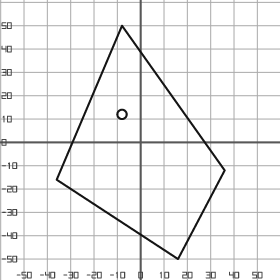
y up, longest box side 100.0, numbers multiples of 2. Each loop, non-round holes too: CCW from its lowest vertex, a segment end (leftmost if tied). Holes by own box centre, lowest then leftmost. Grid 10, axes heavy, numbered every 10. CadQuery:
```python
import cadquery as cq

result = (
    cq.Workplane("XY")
    .moveTo(16.0, -50.0)
    .lineTo(36.0, -12.0)
    .lineTo(-8.0, 50.0)
    .lineTo(-36.0, -16.0)
    .close()
    .moveTo(-8.0, 12.0)
    .circle(2.0)
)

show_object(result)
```